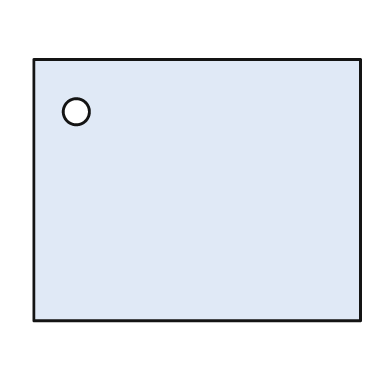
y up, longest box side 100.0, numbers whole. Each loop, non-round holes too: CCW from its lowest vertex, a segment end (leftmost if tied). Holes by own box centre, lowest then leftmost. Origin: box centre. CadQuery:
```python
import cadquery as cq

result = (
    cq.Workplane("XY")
    .moveTo(-50.0, -40.0)
    .lineTo(50.0, -40.0)
    .lineTo(50.0, 40.0)
    .lineTo(-50.0, 40.0)
    .close()
    .moveTo(-37.0, 24.0)
    .circle(4.0)
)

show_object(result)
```